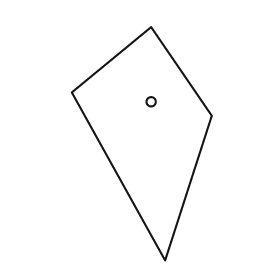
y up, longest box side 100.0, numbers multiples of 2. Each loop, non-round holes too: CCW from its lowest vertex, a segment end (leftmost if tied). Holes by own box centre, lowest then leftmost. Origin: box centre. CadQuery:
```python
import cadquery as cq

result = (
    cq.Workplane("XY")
    .moveTo(10.0, -50.0)
    .lineTo(30.0, 12.0)
    .lineTo(4.0, 50.0)
    .lineTo(-30.0, 22.0)
    .close()
    .moveTo(4.0, 18.0)
    .circle(2.0)
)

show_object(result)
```